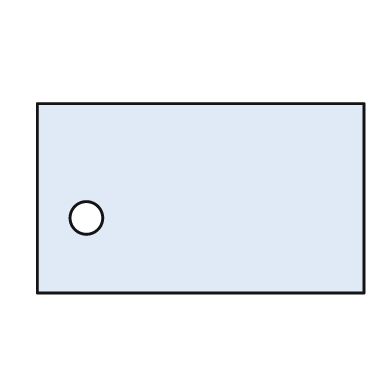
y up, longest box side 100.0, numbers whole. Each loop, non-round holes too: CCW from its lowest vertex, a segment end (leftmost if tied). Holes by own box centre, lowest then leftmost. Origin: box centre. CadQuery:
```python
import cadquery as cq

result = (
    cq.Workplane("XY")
    .moveTo(-50.0, -29.0)
    .lineTo(50.0, -29.0)
    .lineTo(50.0, 29.0)
    .lineTo(-50.0, 29.0)
    .close()
    .moveTo(-35.0, -6.0)
    .circle(5.0)
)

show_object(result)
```